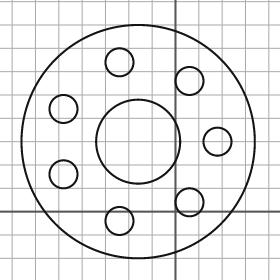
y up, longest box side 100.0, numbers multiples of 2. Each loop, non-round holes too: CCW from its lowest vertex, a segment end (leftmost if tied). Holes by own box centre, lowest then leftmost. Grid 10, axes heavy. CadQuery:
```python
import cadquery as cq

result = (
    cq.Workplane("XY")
    .moveTo(-16.0, 30.0)
    .circle(50.0)
    .moveTo(-24.0, -4.0)
    .circle(6.0)
    .moveTo(6.0, 4.0)
    .circle(6.0)
    .moveTo(-48.0, 16.0)
    .circle(6.0)
    .moveTo(-16.0, 30.0)
    .circle(18.0)
    .moveTo(18.0, 30.0)
    .circle(6.0)
    .moveTo(-48.0, 44.0)
    .circle(6.0)
    .moveTo(6.0, 56.0)
    .circle(6.0)
    .moveTo(-24.0, 64.0)
    .circle(6.0)
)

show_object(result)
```